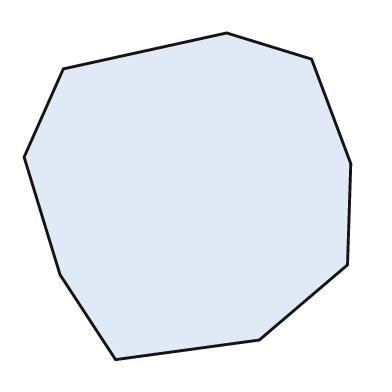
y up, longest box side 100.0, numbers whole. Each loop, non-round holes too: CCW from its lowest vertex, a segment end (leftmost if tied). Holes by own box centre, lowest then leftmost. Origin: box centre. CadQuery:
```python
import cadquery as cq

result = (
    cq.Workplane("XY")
    .moveTo(-22.0, -50.0)
    .lineTo(22.0, -44.0)
    .lineTo(49.0, -21.0)
    .lineTo(50.0, 10.0)
    .lineTo(38.0, 42.0)
    .lineTo(12.0, 50.0)
    .lineTo(-38.0, 39.0)
    .lineTo(-50.0, 12.0)
    .lineTo(-39.0, -24.0)
    .close()
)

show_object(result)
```